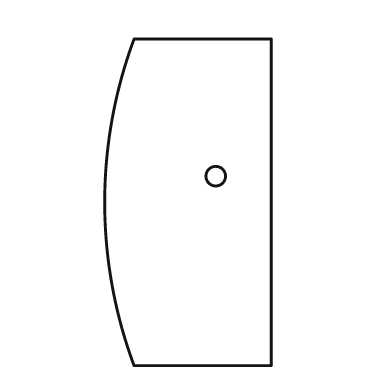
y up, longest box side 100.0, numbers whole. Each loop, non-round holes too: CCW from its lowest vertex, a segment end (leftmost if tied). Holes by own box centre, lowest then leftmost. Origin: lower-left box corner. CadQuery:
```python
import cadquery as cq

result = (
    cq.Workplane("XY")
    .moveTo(9.0, 0.0)
    .lineTo(51.0, 0.0)
    .lineTo(51.0, 100.0)
    .lineTo(9.0, 100.0)
    .threePointArc((0.0, 50.0), (9.0, 0.0))
    .close()
    .moveTo(34.0, 58.0)
    .circle(3.0)
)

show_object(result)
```